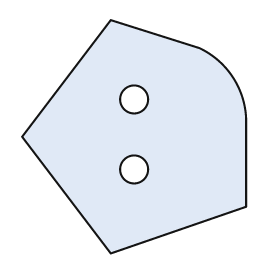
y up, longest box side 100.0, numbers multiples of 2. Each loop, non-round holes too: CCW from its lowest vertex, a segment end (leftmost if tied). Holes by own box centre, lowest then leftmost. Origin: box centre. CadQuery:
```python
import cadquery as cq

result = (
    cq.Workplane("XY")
    .moveTo(-10.0, -50.0)
    .lineTo(48.0, -30.0)
    .lineTo(48.0, 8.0)
    .threePointArc((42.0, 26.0), (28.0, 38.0))
    .lineTo(-10.0, 50.0)
    .lineTo(-48.0, 0.0)
    .close()
    .moveTo(0.0, -14.0)
    .circle(6.0)
    .moveTo(0.0, 16.0)
    .circle(6.0)
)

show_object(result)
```